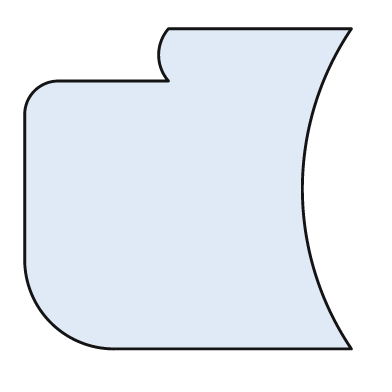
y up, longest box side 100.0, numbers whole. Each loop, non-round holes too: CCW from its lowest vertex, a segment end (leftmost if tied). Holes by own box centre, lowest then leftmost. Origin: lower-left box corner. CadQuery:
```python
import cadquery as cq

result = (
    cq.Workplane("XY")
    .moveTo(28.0, 0.0)
    .lineTo(100.0, 0.0)
    .threePointArc((85.0, 49.0), (100.0, 98.0))
    .lineTo(44.0, 98.0)
    .threePointArc((41.0, 90.0), (44.0, 82.0))
    .lineTo(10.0, 82.0)
    .threePointArc((3.0, 79.0), (0.0, 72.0))
    .lineTo(0.0, 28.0)
    .threePointArc((8.0, 8.0), (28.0, 0.0))
    .close()
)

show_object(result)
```